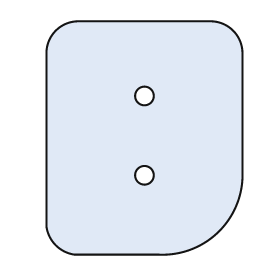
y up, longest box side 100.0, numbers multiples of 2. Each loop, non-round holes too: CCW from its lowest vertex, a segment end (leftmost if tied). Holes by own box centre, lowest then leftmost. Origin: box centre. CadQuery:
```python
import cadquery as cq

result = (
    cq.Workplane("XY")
    .moveTo(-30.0, -50.0)
    .lineTo(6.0, -50.0)
    .threePointArc((32.0, -40.0), (42.0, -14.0))
    .lineTo(42.0, 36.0)
    .threePointArc((38.0, 46.0), (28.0, 50.0))
    .lineTo(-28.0, 50.0)
    .threePointArc((-38.0, 46.0), (-42.0, 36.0))
    .lineTo(-42.0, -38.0)
    .threePointArc((-38.0, -46.0), (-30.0, -50.0))
    .close()
    .moveTo(0.0, -16.0)
    .circle(4.0)
    .moveTo(0.0, 18.0)
    .circle(4.0)
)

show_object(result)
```